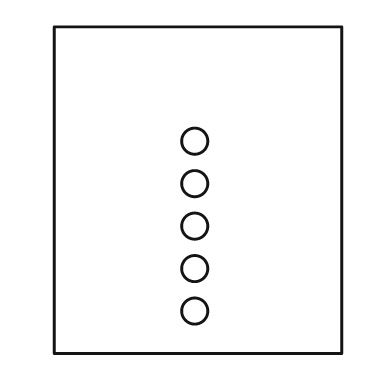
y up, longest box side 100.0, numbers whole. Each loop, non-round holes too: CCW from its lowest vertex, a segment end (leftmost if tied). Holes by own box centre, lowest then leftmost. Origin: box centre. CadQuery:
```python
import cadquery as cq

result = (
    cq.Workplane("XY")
    .moveTo(-44.0, -50.0)
    .lineTo(44.0, -50.0)
    .lineTo(44.0, 50.0)
    .lineTo(-44.0, 50.0)
    .close()
    .moveTo(-1.0, -37.0)
    .circle(4.0)
    .moveTo(-1.0, -24.0)
    .circle(4.0)
    .moveTo(-1.0, -11.0)
    .circle(4.0)
    .moveTo(-1.0, 2.0)
    .circle(4.0)
    .moveTo(-1.0, 15.0)
    .circle(4.0)
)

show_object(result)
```